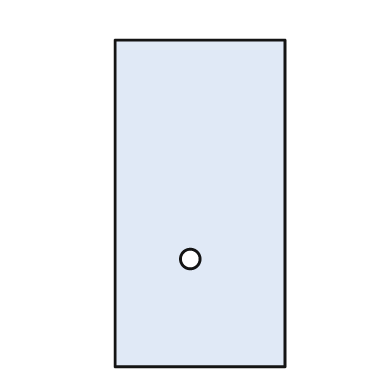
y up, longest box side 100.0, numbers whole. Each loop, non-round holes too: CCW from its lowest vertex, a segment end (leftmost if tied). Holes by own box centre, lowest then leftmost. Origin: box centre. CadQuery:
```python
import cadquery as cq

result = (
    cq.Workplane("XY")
    .moveTo(-26.0, -50.0)
    .lineTo(26.0, -50.0)
    .lineTo(26.0, 50.0)
    .lineTo(-26.0, 50.0)
    .close()
    .moveTo(-3.0, -17.0)
    .circle(3.0)
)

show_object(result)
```